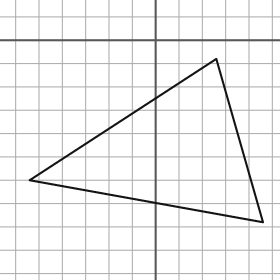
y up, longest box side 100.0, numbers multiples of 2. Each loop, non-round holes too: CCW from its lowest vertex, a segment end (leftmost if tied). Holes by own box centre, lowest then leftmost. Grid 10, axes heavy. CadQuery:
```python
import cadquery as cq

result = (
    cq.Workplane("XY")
    .moveTo(46.0, -78.0)
    .lineTo(26.0, -8.0)
    .lineTo(-54.0, -60.0)
    .close()
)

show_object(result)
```